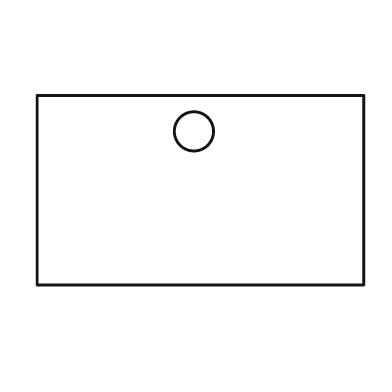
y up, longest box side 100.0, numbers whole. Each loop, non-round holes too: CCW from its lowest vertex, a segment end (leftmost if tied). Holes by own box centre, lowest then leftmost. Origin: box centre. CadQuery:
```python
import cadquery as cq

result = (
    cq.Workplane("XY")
    .moveTo(-50.0, -29.0)
    .lineTo(50.0, -29.0)
    .lineTo(50.0, 29.0)
    .lineTo(-50.0, 29.0)
    .close()
    .moveTo(-2.0, 18.0)
    .circle(6.0)
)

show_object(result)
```